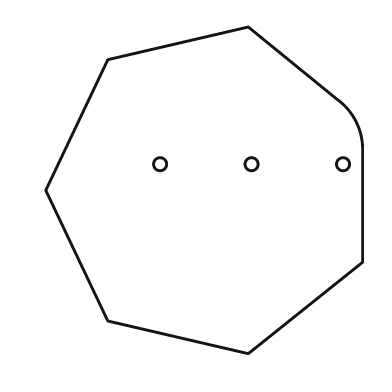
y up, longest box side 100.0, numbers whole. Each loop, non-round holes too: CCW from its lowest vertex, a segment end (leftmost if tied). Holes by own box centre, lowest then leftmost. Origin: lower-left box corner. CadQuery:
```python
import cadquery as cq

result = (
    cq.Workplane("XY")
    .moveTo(62.0, 0.0)
    .lineTo(97.0, 28.0)
    .lineTo(97.0, 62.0)
    .threePointArc((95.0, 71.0), (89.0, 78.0))
    .lineTo(62.0, 100.0)
    .lineTo(19.0, 90.0)
    .lineTo(0.0, 50.0)
    .lineTo(19.0, 10.0)
    .close()
    .moveTo(35.0, 58.0)
    .circle(2.0)
    .moveTo(63.0, 58.0)
    .circle(2.0)
    .moveTo(91.0, 58.0)
    .circle(2.0)
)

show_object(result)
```